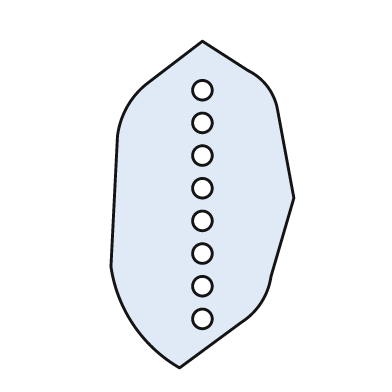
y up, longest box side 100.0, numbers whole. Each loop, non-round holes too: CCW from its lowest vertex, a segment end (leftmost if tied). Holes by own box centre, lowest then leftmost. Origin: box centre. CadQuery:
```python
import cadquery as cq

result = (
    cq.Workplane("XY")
    .moveTo(-7.0, -50.0)
    .lineTo(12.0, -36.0)
    .threePointArc((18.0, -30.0), (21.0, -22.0))
    .lineTo(28.0, 2.0)
    .lineTo(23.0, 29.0)
    .threePointArc((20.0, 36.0), (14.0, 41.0))
    .lineTo(0.0, 50.0)
    .lineTo(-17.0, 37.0)
    .threePointArc((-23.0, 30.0), (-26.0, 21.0))
    .lineTo(-28.0, -19.0)
    .threePointArc((-21.0, -37.0), (-7.0, -50.0))
    .close()
    .moveTo(0.0, -35.0)
    .circle(3.0)
    .moveTo(0.0, -25.0)
    .circle(3.0)
    .moveTo(0.0, -15.0)
    .circle(3.0)
    .moveTo(0.0, -5.0)
    .circle(3.0)
    .moveTo(0.0, 5.0)
    .circle(3.0)
    .moveTo(0.0, 15.0)
    .circle(3.0)
    .moveTo(0.0, 25.0)
    .circle(3.0)
    .moveTo(0.0, 35.0)
    .circle(3.0)
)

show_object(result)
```